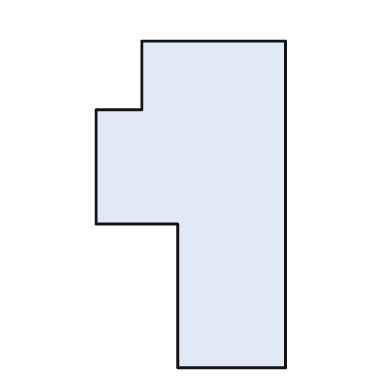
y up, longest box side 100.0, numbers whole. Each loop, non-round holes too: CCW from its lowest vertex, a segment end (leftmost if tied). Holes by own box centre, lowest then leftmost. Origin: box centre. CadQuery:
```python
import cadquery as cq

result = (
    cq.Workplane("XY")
    .moveTo(-4.0, -50.0)
    .lineTo(29.0, -50.0)
    .lineTo(29.0, 50.0)
    .lineTo(-15.0, 50.0)
    .lineTo(-15.0, 29.0)
    .lineTo(-29.0, 29.0)
    .lineTo(-29.0, -6.0)
    .lineTo(-4.0, -6.0)
    .close()
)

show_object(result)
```